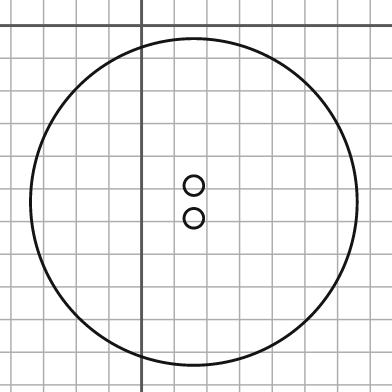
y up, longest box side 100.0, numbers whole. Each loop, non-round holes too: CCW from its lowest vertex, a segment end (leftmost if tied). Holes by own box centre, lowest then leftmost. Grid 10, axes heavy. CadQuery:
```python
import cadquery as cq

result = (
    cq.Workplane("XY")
    .moveTo(16.0, -54.0)
    .circle(50.0)
    .moveTo(16.0, -59.0)
    .circle(3.0)
    .moveTo(16.0, -49.0)
    .circle(3.0)
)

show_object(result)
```